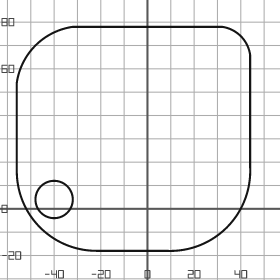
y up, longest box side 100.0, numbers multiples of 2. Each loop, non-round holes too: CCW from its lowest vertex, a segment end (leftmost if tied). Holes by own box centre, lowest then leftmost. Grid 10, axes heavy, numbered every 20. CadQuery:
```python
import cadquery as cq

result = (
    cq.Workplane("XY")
    .moveTo(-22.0, -18.0)
    .lineTo(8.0, -18.0)
    .threePointArc((34.0, -8.0), (44.0, 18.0))
    .lineTo(44.0, 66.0)
    .threePointArc((40.0, 74.0), (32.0, 78.0))
    .lineTo(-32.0, 78.0)
    .threePointArc((-48.0, 70.0), (-56.0, 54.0))
    .lineTo(-56.0, 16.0)
    .threePointArc((-46.0, -8.0), (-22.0, -18.0))
    .close()
    .moveTo(-40.0, 4.0)
    .circle(8.0)
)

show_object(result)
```